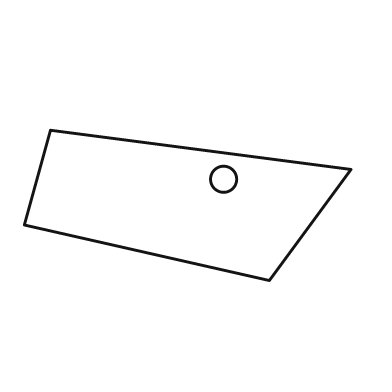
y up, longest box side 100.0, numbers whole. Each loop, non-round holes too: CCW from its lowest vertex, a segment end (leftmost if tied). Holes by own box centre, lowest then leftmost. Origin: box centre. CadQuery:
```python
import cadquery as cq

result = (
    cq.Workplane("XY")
    .moveTo(25.0, -23.0)
    .lineTo(50.0, 11.0)
    .lineTo(-42.0, 23.0)
    .lineTo(-50.0, -6.0)
    .close()
    .moveTo(11.0, 8.0)
    .circle(4.0)
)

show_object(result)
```